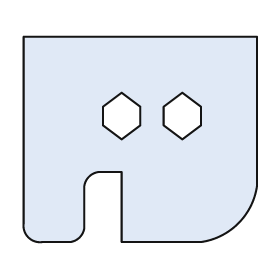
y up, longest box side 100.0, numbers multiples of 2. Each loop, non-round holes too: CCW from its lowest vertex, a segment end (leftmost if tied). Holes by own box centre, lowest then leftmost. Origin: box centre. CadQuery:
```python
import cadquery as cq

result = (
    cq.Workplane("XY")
    .moveTo(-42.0, -44.0)
    .lineTo(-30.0, -44.0)
    .threePointArc((-26.0, -42.0), (-24.0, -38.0))
    .lineTo(-24.0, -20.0)
    .threePointArc((-22.0, -16.0), (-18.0, -14.0))
    .lineTo(-8.0, -14.0)
    .lineTo(-8.0, -44.0)
    .lineTo(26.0, -44.0)
    .threePointArc((42.0, -36.0), (50.0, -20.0))
    .lineTo(50.0, 44.0)
    .lineTo(-50.0, 44.0)
    .lineTo(-50.0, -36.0)
    .threePointArc((-48.0, -42.0), (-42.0, -44.0))
    .close()
    .moveTo(-8.0, 0.0)
    .lineTo(0.0, 6.0)
    .lineTo(0.0, 14.0)
    .lineTo(-8.0, 20.0)
    .lineTo(-16.0, 14.0)
    .lineTo(-16.0, 6.0)
    .close()
    .moveTo(18.0, 0.0)
    .lineTo(26.0, 6.0)
    .lineTo(26.0, 14.0)
    .lineTo(18.0, 20.0)
    .lineTo(10.0, 14.0)
    .lineTo(10.0, 6.0)
    .close()
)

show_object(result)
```